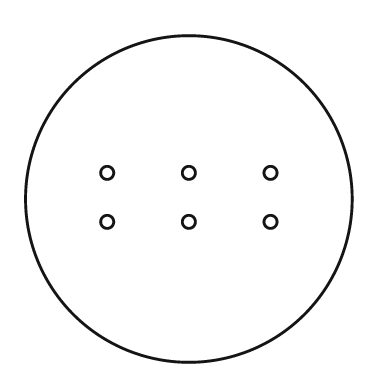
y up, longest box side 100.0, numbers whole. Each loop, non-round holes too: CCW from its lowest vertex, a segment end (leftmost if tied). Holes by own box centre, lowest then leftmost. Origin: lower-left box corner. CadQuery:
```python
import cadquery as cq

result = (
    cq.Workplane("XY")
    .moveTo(50.0, 50.0)
    .circle(50.0)
    .moveTo(25.0, 43.0)
    .circle(2.0)
    .moveTo(50.0, 43.0)
    .circle(2.0)
    .moveTo(75.0, 43.0)
    .circle(2.0)
    .moveTo(25.0, 58.0)
    .circle(2.0)
    .moveTo(50.0, 58.0)
    .circle(2.0)
    .moveTo(75.0, 58.0)
    .circle(2.0)
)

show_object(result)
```